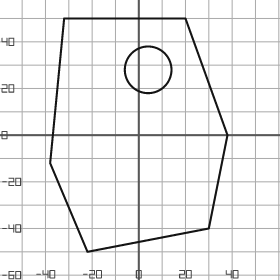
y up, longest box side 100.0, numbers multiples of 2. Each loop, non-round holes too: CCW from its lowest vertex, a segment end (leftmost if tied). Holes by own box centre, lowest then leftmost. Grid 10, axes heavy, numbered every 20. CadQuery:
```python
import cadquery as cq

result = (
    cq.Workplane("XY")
    .moveTo(-22.0, -50.0)
    .lineTo(30.0, -40.0)
    .lineTo(38.0, 0.0)
    .lineTo(20.0, 50.0)
    .lineTo(-32.0, 50.0)
    .lineTo(-38.0, -12.0)
    .close()
    .moveTo(4.0, 28.0)
    .circle(10.0)
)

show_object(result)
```